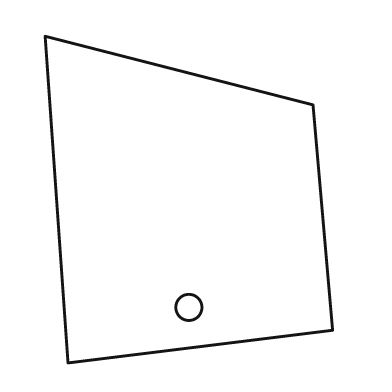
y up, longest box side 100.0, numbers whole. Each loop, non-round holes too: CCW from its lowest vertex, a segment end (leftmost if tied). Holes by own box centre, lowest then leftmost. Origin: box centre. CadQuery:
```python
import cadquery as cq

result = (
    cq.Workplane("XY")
    .moveTo(-37.0, -50.0)
    .lineTo(44.0, -40.0)
    .lineTo(38.0, 29.0)
    .lineTo(-44.0, 50.0)
    .close()
    .moveTo(0.0, -33.0)
    .circle(4.0)
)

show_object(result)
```